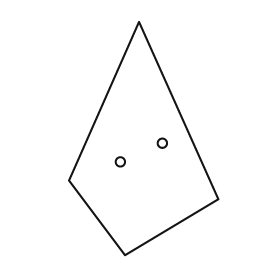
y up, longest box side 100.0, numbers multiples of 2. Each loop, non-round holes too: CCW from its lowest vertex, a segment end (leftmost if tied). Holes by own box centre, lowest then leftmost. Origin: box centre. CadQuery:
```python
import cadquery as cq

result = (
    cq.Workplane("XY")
    .moveTo(-8.0, -50.0)
    .lineTo(32.0, -26.0)
    .lineTo(-2.0, 50.0)
    .lineTo(-32.0, -18.0)
    .close()
    .moveTo(-10.0, -10.0)
    .circle(2.0)
    .moveTo(8.0, -2.0)
    .circle(2.0)
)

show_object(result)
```